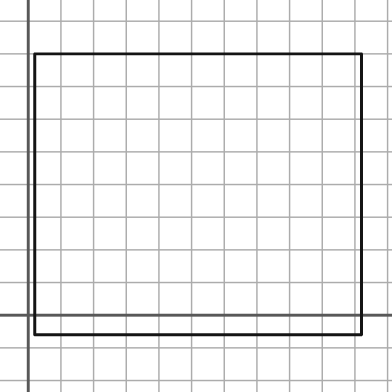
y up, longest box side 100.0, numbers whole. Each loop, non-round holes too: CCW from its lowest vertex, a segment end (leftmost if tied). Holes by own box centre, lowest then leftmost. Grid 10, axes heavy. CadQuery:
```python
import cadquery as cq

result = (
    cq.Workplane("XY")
    .moveTo(2.0, -6.0)
    .lineTo(102.0, -6.0)
    .lineTo(102.0, 80.0)
    .lineTo(2.0, 80.0)
    .close()
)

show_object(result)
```